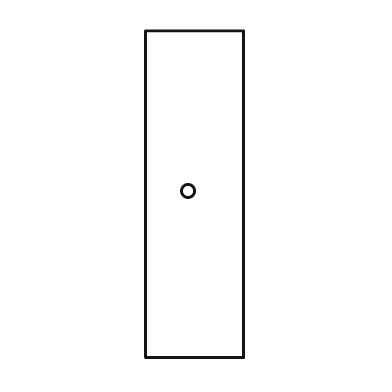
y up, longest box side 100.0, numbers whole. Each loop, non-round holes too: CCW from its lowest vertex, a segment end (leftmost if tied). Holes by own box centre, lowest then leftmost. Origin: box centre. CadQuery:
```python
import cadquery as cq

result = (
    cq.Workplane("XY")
    .moveTo(-15.0, -50.0)
    .lineTo(15.0, -50.0)
    .lineTo(15.0, 50.0)
    .lineTo(-15.0, 50.0)
    .close()
    .moveTo(-2.0, 1.0)
    .circle(2.0)
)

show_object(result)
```